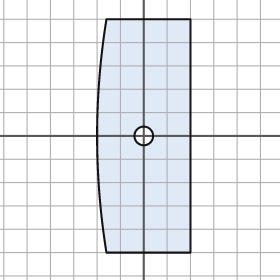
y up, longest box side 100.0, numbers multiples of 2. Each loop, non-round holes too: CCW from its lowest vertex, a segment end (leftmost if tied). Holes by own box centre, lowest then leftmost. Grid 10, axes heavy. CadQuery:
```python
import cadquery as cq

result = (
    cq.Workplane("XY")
    .moveTo(-16.0, -50.0)
    .lineTo(20.0, -50.0)
    .lineTo(20.0, 50.0)
    .lineTo(-16.0, 50.0)
    .threePointArc((-20.0, 0.0), (-16.0, -50.0))
    .close()
    .moveTo(0.0, 0.0)
    .circle(4.0)
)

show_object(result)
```